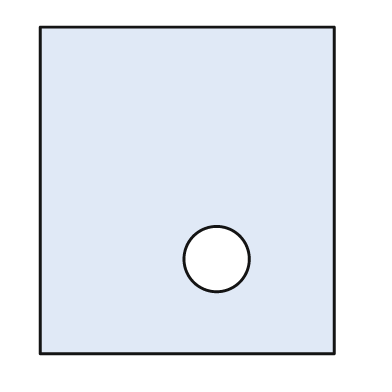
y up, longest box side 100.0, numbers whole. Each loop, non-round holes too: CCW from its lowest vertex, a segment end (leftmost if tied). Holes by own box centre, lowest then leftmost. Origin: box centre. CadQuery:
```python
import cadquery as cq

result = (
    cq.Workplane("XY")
    .moveTo(-45.0, -50.0)
    .lineTo(45.0, -50.0)
    .lineTo(45.0, 50.0)
    .lineTo(-45.0, 50.0)
    .close()
    .moveTo(9.0, -21.0)
    .circle(10.0)
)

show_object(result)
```